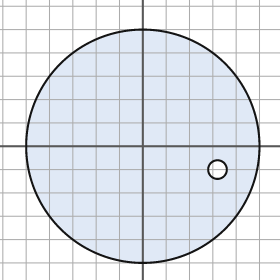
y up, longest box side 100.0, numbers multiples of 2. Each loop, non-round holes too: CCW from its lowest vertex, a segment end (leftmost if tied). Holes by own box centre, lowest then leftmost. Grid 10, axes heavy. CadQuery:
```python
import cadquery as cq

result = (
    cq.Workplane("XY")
    .moveTo(0.0, 0.0)
    .circle(50.0)
    .moveTo(32.0, -10.0)
    .circle(4.0)
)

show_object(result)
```